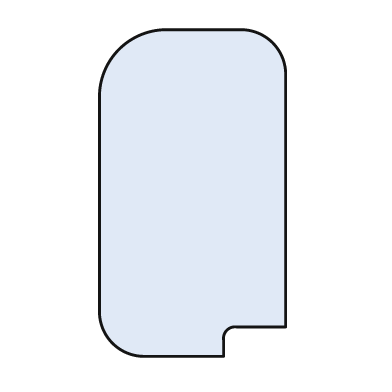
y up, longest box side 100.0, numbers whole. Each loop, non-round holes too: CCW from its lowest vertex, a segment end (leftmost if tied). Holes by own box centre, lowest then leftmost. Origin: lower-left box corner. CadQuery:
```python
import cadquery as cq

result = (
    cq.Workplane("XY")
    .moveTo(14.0, 0.0)
    .lineTo(38.0, 0.0)
    .lineTo(38.0, 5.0)
    .threePointArc((39.0, 8.0), (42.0, 9.0))
    .lineTo(57.0, 9.0)
    .lineTo(57.0, 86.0)
    .threePointArc((53.0, 96.0), (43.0, 100.0))
    .lineTo(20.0, 100.0)
    .threePointArc((6.0, 94.0), (0.0, 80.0))
    .lineTo(0.0, 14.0)
    .threePointArc((4.0, 4.0), (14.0, 0.0))
    .close()
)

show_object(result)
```